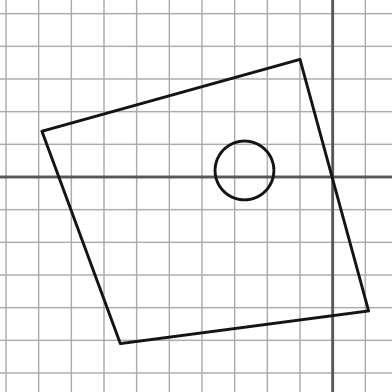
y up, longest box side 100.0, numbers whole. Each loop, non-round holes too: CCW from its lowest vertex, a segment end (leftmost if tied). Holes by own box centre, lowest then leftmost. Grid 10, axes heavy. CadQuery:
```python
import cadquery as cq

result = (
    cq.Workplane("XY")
    .moveTo(-65.0, -51.0)
    .lineTo(11.0, -41.0)
    .lineTo(-10.0, 36.0)
    .lineTo(-89.0, 14.0)
    .close()
    .moveTo(-27.0, 2.0)
    .circle(9.0)
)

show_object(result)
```